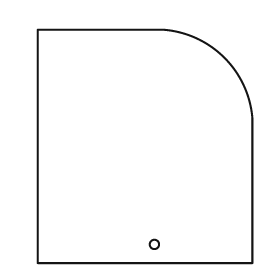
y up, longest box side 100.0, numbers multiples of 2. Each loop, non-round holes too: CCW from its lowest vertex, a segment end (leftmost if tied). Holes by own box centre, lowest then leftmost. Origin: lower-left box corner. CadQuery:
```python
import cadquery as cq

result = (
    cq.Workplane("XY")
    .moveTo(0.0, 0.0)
    .lineTo(92.0, 0.0)
    .lineTo(92.0, 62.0)
    .threePointArc((80.0, 88.0), (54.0, 100.0))
    .lineTo(0.0, 100.0)
    .close()
    .moveTo(50.0, 8.0)
    .circle(2.0)
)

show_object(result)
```